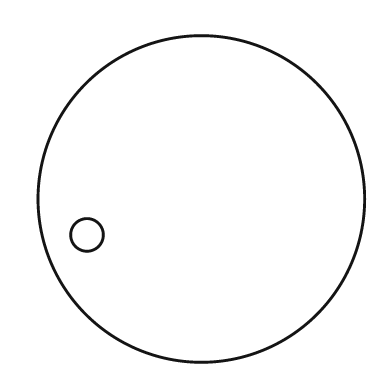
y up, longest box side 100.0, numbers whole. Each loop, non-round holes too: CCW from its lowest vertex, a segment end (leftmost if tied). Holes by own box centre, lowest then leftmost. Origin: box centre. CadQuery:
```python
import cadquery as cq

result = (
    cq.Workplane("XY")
    .moveTo(0.0, 0.0)
    .circle(50.0)
    .moveTo(-35.0, -11.0)
    .circle(5.0)
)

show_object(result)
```